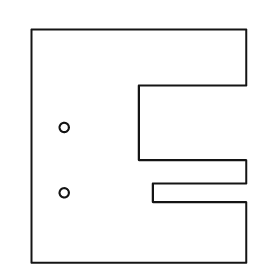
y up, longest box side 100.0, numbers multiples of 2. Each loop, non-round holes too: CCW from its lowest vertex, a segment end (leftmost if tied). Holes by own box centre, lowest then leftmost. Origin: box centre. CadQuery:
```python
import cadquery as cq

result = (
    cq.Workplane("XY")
    .moveTo(-46.0, -50.0)
    .lineTo(46.0, -50.0)
    .lineTo(46.0, -24.0)
    .lineTo(6.0, -24.0)
    .lineTo(6.0, -16.0)
    .lineTo(46.0, -16.0)
    .lineTo(46.0, -6.0)
    .lineTo(0.0, -6.0)
    .lineTo(0.0, 26.0)
    .lineTo(46.0, 26.0)
    .lineTo(46.0, 50.0)
    .lineTo(-46.0, 50.0)
    .close()
    .moveTo(-32.0, -20.0)
    .circle(2.0)
    .moveTo(-32.0, 8.0)
    .circle(2.0)
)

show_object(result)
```